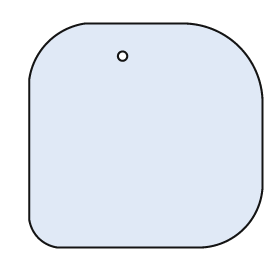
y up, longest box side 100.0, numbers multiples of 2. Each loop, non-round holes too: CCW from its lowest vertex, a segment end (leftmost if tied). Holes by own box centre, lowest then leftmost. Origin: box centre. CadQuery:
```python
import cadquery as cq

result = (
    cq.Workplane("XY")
    .moveTo(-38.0, -48.0)
    .lineTo(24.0, -48.0)
    .threePointArc((42.0, -40.0), (50.0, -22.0))
    .lineTo(50.0, 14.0)
    .threePointArc((40.0, 38.0), (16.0, 48.0))
    .lineTo(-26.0, 48.0)
    .threePointArc((-42.0, 40.0), (-50.0, 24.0))
    .lineTo(-50.0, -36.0)
    .threePointArc((-46.0, -44.0), (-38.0, -48.0))
    .close()
    .moveTo(-10.0, 34.0)
    .circle(2.0)
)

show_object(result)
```